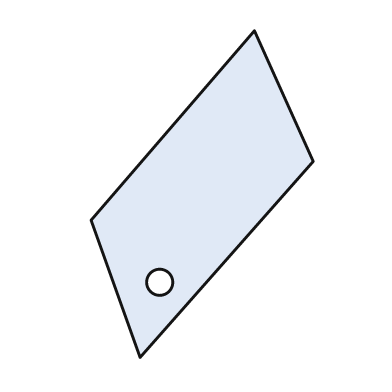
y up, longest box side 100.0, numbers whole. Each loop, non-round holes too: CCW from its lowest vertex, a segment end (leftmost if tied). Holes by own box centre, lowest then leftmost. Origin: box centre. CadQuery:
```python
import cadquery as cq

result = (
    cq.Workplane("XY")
    .moveTo(-19.0, -50.0)
    .lineTo(34.0, 10.0)
    .lineTo(16.0, 50.0)
    .lineTo(-34.0, -8.0)
    .close()
    .moveTo(-13.0, -27.0)
    .circle(4.0)
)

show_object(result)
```